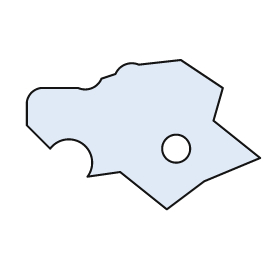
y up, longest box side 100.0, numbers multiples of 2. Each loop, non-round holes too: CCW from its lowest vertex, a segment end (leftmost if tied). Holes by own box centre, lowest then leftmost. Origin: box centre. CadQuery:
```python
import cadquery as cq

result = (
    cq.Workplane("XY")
    .moveTo(10.0, -32.0)
    .lineTo(26.0, -20.0)
    .lineTo(50.0, -10.0)
    .lineTo(30.0, 6.0)
    .lineTo(34.0, 20.0)
    .lineTo(16.0, 32.0)
    .lineTo(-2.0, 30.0)
    .threePointArc((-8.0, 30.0), (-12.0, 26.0))
    .lineTo(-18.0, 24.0)
    .threePointArc((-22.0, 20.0), (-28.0, 20.0))
    .lineTo(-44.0, 20.0)
    .threePointArc((-48.0, 18.0), (-50.0, 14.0))
    .lineTo(-50.0, 4.0)
    .lineTo(-40.0, -6.0)
    .threePointArc((-26.0, -4.0), (-24.0, -18.0))
    .lineTo(-10.0, -16.0)
    .close()
    .moveTo(14.0, -6.0)
    .circle(6.0)
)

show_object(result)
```